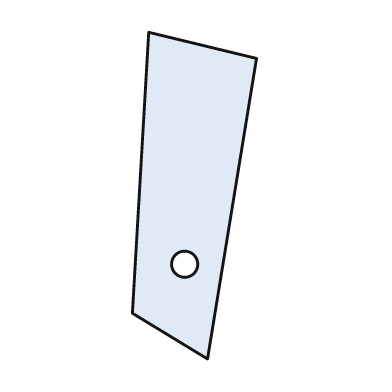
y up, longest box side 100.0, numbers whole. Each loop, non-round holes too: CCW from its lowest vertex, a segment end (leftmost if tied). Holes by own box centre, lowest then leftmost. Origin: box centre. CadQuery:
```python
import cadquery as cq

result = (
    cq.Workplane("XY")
    .moveTo(4.0, -50.0)
    .lineTo(19.0, 42.0)
    .lineTo(-14.0, 50.0)
    .lineTo(-19.0, -36.0)
    .close()
    .moveTo(-3.0, -21.0)
    .circle(4.0)
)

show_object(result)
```